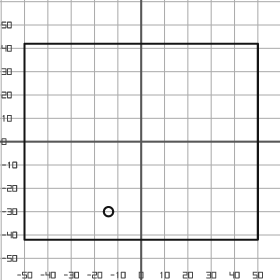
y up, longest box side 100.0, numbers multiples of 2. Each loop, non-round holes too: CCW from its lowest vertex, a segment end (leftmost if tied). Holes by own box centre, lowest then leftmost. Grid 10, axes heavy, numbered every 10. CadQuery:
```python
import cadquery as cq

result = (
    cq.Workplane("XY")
    .moveTo(-50.0, -42.0)
    .lineTo(50.0, -42.0)
    .lineTo(50.0, 42.0)
    .lineTo(-50.0, 42.0)
    .close()
    .moveTo(-14.0, -30.0)
    .circle(2.0)
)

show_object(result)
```